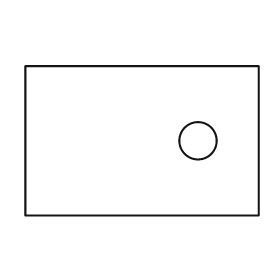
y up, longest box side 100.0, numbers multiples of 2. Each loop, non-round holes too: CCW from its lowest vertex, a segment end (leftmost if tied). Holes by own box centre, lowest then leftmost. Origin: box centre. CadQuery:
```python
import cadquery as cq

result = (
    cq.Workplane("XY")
    .moveTo(-50.0, -32.0)
    .lineTo(50.0, -32.0)
    .lineTo(50.0, 32.0)
    .lineTo(-50.0, 32.0)
    .close()
    .moveTo(24.0, 0.0)
    .circle(8.0)
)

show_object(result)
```